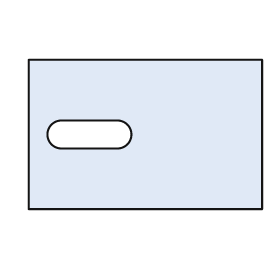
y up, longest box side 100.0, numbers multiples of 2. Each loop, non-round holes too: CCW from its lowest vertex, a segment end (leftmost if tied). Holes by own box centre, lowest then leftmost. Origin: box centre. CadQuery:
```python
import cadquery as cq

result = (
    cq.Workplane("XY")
    .moveTo(-50.0, -32.0)
    .lineTo(50.0, -32.0)
    .lineTo(50.0, 32.0)
    .lineTo(-50.0, 32.0)
    .close()
    .moveTo(-36.0, -6.0)
    .lineTo(-12.0, -6.0)
    .threePointArc((-6.0, 0.0), (-12.0, 6.0))
    .lineTo(-36.0, 6.0)
    .threePointArc((-42.0, 0.0), (-36.0, -6.0))
    .close()
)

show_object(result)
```